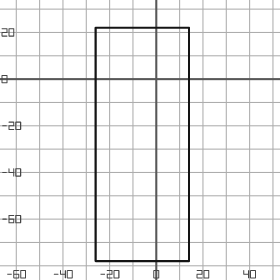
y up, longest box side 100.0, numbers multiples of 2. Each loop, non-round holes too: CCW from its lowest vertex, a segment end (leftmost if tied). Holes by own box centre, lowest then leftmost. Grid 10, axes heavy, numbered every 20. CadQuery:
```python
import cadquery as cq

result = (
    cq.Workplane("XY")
    .moveTo(-26.0, -78.0)
    .lineTo(14.0, -78.0)
    .lineTo(14.0, 22.0)
    .lineTo(-26.0, 22.0)
    .close()
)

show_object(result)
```